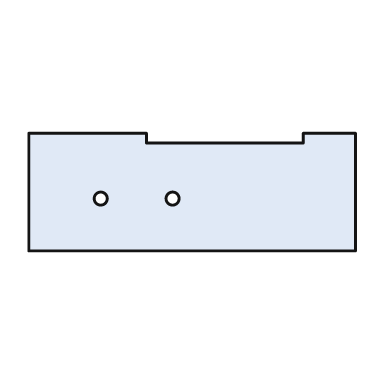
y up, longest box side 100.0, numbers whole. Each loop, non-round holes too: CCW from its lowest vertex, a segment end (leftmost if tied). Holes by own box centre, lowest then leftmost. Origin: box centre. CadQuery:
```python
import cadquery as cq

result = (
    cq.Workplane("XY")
    .moveTo(-50.0, -18.0)
    .lineTo(50.0, -18.0)
    .lineTo(50.0, 18.0)
    .lineTo(34.0, 18.0)
    .lineTo(34.0, 15.0)
    .lineTo(-14.0, 15.0)
    .lineTo(-14.0, 18.0)
    .lineTo(-50.0, 18.0)
    .close()
    .moveTo(-28.0, -2.0)
    .circle(2.0)
    .moveTo(-6.0, -2.0)
    .circle(2.0)
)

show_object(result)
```